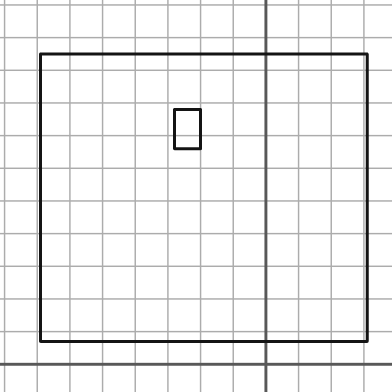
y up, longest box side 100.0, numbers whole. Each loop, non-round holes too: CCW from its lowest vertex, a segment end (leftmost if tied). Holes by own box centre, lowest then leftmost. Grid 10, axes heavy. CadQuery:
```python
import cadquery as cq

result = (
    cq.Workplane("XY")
    .moveTo(-69.0, 7.0)
    .lineTo(31.0, 7.0)
    .lineTo(31.0, 95.0)
    .lineTo(-69.0, 95.0)
    .close()
    .moveTo(-28.0, 66.0)
    .lineTo(-20.0, 66.0)
    .lineTo(-20.0, 78.0)
    .lineTo(-28.0, 78.0)
    .close()
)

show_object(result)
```